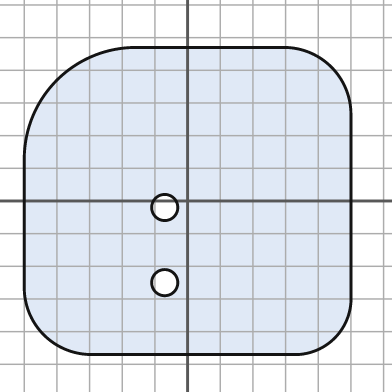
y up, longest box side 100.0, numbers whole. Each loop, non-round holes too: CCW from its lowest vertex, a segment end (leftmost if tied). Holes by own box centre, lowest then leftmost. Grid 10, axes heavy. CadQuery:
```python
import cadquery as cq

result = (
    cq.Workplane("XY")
    .moveTo(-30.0, -47.0)
    .lineTo(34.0, -47.0)
    .threePointArc((45.0, -42.0), (50.0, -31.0))
    .lineTo(50.0, 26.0)
    .threePointArc((44.0, 41.0), (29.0, 47.0))
    .lineTo(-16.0, 47.0)
    .threePointArc((-40.0, 37.0), (-50.0, 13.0))
    .lineTo(-50.0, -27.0)
    .threePointArc((-44.0, -41.0), (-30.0, -47.0))
    .close()
    .moveTo(-7.0, -25.0)
    .circle(4.0)
    .moveTo(-7.0, -2.0)
    .circle(4.0)
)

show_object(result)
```